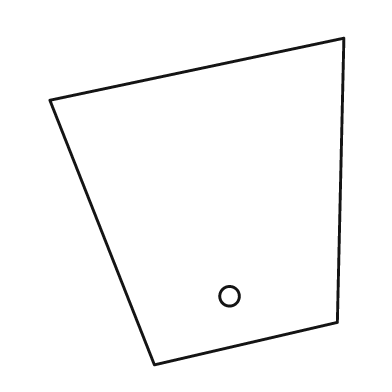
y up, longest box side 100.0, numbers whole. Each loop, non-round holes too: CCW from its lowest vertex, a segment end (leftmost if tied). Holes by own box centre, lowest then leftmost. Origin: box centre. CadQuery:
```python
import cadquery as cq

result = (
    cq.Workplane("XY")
    .moveTo(-13.0, -50.0)
    .lineTo(43.0, -37.0)
    .lineTo(45.0, 50.0)
    .lineTo(-45.0, 31.0)
    .close()
    .moveTo(10.0, -29.0)
    .circle(3.0)
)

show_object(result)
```